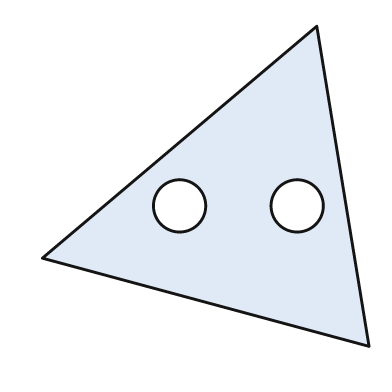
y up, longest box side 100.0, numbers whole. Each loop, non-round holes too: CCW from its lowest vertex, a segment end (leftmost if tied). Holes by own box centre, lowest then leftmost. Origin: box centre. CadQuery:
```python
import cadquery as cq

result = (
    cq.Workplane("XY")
    .moveTo(50.0, -49.0)
    .lineTo(34.0, 49.0)
    .lineTo(-50.0, -22.0)
    .close()
    .moveTo(-8.0, -6.0)
    .circle(8.0)
    .moveTo(28.0, -6.0)
    .circle(8.0)
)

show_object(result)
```